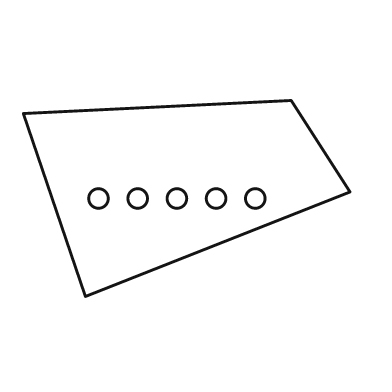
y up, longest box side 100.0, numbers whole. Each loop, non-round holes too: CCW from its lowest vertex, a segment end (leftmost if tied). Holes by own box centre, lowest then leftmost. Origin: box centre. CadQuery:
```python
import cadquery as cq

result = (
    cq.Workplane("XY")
    .moveTo(-31.0, -30.0)
    .lineTo(50.0, 2.0)
    .lineTo(32.0, 30.0)
    .lineTo(-50.0, 26.0)
    .close()
    .moveTo(-27.0, 0.0)
    .circle(3.0)
    .moveTo(-15.0, 0.0)
    .circle(3.0)
    .moveTo(-3.0, 0.0)
    .circle(3.0)
    .moveTo(9.0, 0.0)
    .circle(3.0)
    .moveTo(21.0, 0.0)
    .circle(3.0)
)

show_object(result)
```